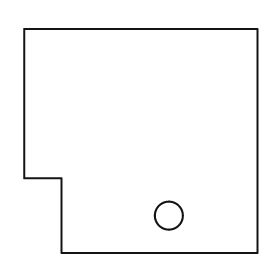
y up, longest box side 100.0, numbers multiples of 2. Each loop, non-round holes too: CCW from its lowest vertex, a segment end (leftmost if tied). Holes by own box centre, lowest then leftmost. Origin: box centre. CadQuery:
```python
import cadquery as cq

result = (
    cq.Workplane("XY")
    .moveTo(-34.0, -48.0)
    .lineTo(50.0, -48.0)
    .lineTo(50.0, 48.0)
    .lineTo(-50.0, 48.0)
    .lineTo(-50.0, -16.0)
    .lineTo(-34.0, -16.0)
    .close()
    .moveTo(12.0, -32.0)
    .circle(6.0)
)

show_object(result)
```